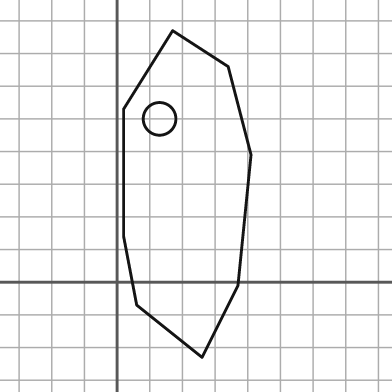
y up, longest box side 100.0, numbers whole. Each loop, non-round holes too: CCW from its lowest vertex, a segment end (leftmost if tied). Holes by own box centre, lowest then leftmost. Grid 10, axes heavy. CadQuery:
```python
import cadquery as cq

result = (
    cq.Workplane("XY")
    .moveTo(26.0, -23.0)
    .lineTo(37.0, -1.0)
    .lineTo(41.0, 39.0)
    .lineTo(34.0, 66.0)
    .lineTo(17.0, 77.0)
    .lineTo(2.0, 53.0)
    .lineTo(2.0, 14.0)
    .lineTo(6.0, -7.0)
    .close()
    .moveTo(13.0, 50.0)
    .circle(5.0)
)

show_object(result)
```